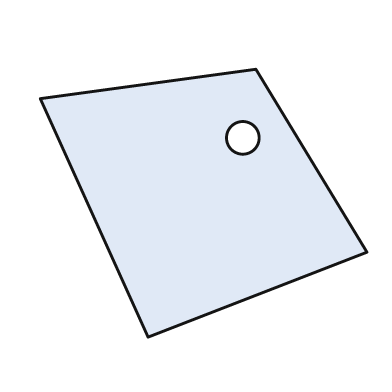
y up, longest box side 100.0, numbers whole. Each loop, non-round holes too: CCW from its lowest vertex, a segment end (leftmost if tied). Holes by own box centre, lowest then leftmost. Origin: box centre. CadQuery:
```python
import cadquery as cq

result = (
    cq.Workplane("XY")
    .moveTo(-17.0, -41.0)
    .lineTo(50.0, -15.0)
    .lineTo(16.0, 41.0)
    .lineTo(-50.0, 32.0)
    .close()
    .moveTo(12.0, 20.0)
    .circle(5.0)
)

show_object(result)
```